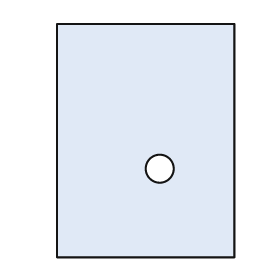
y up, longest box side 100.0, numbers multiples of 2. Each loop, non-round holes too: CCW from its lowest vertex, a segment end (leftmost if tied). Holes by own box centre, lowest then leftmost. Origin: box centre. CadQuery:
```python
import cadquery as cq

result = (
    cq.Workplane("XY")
    .moveTo(-38.0, -50.0)
    .lineTo(38.0, -50.0)
    .lineTo(38.0, 50.0)
    .lineTo(-38.0, 50.0)
    .close()
    .moveTo(6.0, -12.0)
    .circle(6.0)
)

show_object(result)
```